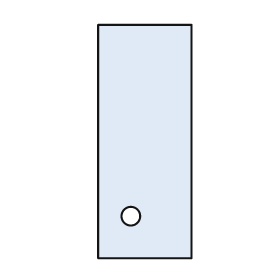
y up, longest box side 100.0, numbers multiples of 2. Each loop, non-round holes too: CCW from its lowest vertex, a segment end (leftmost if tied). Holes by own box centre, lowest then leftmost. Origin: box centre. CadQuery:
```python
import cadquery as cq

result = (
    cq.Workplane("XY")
    .moveTo(-20.0, -50.0)
    .lineTo(20.0, -50.0)
    .lineTo(20.0, 50.0)
    .lineTo(-20.0, 50.0)
    .close()
    .moveTo(-6.0, -32.0)
    .circle(4.0)
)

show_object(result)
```